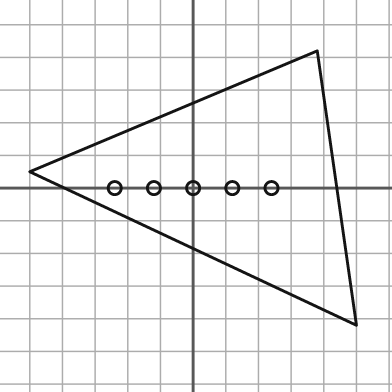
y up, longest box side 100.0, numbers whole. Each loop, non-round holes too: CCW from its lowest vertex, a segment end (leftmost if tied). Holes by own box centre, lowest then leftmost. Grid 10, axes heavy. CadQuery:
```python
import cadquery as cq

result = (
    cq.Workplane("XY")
    .moveTo(50.0, -42.0)
    .lineTo(38.0, 42.0)
    .lineTo(-50.0, 5.0)
    .close()
    .moveTo(-24.0, 0.0)
    .circle(2.0)
    .moveTo(-12.0, 0.0)
    .circle(2.0)
    .moveTo(0.0, 0.0)
    .circle(2.0)
    .moveTo(12.0, 0.0)
    .circle(2.0)
    .moveTo(24.0, 0.0)
    .circle(2.0)
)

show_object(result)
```